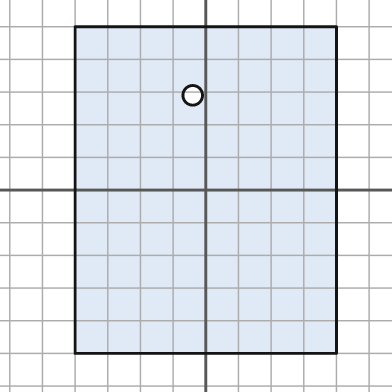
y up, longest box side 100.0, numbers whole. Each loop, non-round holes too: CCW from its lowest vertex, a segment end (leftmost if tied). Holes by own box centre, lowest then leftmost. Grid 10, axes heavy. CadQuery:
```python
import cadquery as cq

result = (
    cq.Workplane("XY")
    .moveTo(-40.0, -50.0)
    .lineTo(40.0, -50.0)
    .lineTo(40.0, 50.0)
    .lineTo(-40.0, 50.0)
    .close()
    .moveTo(-4.0, 29.0)
    .circle(3.0)
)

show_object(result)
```